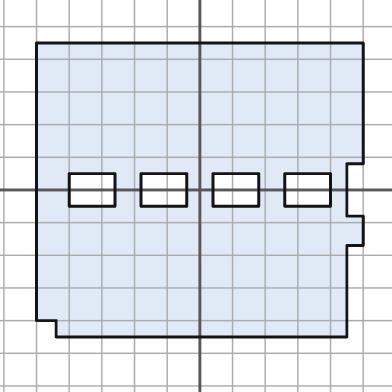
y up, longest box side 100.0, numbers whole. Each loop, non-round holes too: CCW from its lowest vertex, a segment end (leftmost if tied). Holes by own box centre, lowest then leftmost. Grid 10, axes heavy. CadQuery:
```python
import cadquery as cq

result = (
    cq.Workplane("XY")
    .moveTo(-44.0, -45.0)
    .lineTo(45.0, -45.0)
    .lineTo(45.0, -17.0)
    .lineTo(50.0, -17.0)
    .lineTo(50.0, -8.0)
    .lineTo(45.0, -8.0)
    .lineTo(45.0, 8.0)
    .lineTo(50.0, 8.0)
    .lineTo(50.0, 45.0)
    .lineTo(-50.0, 45.0)
    .lineTo(-50.0, -40.0)
    .lineTo(-44.0, -40.0)
    .close()
    .moveTo(-40.0, -5.0)
    .lineTo(-26.0, -5.0)
    .lineTo(-26.0, 5.0)
    .lineTo(-40.0, 5.0)
    .close()
    .moveTo(-18.0, -5.0)
    .lineTo(-4.0, -5.0)
    .lineTo(-4.0, 5.0)
    .lineTo(-18.0, 5.0)
    .close()
    .moveTo(4.0, -5.0)
    .lineTo(18.0, -5.0)
    .lineTo(18.0, 5.0)
    .lineTo(4.0, 5.0)
    .close()
    .moveTo(26.0, -5.0)
    .lineTo(40.0, -5.0)
    .lineTo(40.0, 5.0)
    .lineTo(26.0, 5.0)
    .close()
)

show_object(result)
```